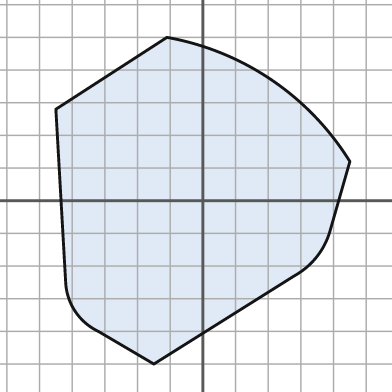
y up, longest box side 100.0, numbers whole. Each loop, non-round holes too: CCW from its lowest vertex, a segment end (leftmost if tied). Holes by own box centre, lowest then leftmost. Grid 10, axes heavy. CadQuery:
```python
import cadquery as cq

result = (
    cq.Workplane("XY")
    .moveTo(-15.0, -50.0)
    .lineTo(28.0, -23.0)
    .threePointArc((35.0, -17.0), (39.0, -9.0))
    .lineTo(45.0, 12.0)
    .threePointArc((21.0, 37.0), (-11.0, 50.0))
    .lineTo(-45.0, 28.0)
    .lineTo(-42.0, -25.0)
    .threePointArc((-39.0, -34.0), (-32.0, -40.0))
    .close()
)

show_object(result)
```